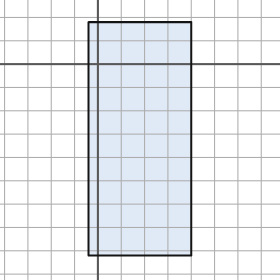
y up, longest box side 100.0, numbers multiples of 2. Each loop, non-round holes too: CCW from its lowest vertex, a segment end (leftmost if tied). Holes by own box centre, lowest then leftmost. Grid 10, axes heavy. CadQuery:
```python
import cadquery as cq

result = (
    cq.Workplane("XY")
    .moveTo(-4.0, -82.0)
    .lineTo(40.0, -82.0)
    .lineTo(40.0, 18.0)
    .lineTo(-4.0, 18.0)
    .close()
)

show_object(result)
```